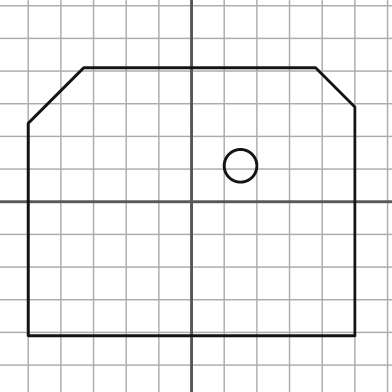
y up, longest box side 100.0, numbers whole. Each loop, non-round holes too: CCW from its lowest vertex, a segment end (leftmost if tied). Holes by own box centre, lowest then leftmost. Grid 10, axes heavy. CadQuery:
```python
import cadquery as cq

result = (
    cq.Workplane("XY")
    .moveTo(-50.0, -41.0)
    .lineTo(50.0, -41.0)
    .lineTo(50.0, 29.0)
    .lineTo(38.0, 41.0)
    .lineTo(-33.0, 41.0)
    .lineTo(-50.0, 24.0)
    .close()
    .moveTo(15.0, 11.0)
    .circle(5.0)
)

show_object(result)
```